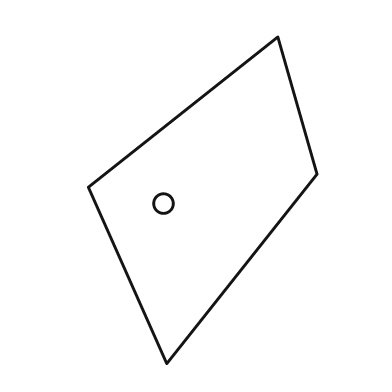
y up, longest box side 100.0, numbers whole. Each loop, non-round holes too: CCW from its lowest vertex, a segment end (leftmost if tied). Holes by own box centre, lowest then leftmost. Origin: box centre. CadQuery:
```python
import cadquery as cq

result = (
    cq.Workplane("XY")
    .moveTo(-11.0, -50.0)
    .lineTo(35.0, 8.0)
    .lineTo(23.0, 50.0)
    .lineTo(-35.0, 4.0)
    .close()
    .moveTo(-12.0, -1.0)
    .circle(3.0)
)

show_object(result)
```